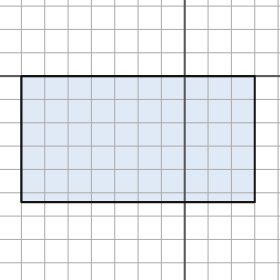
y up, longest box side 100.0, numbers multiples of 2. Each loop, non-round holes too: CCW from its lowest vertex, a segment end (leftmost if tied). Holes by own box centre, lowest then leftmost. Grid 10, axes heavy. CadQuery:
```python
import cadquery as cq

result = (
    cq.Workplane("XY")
    .moveTo(-70.0, -54.0)
    .lineTo(30.0, -54.0)
    .lineTo(30.0, 0.0)
    .lineTo(-70.0, 0.0)
    .close()
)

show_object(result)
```